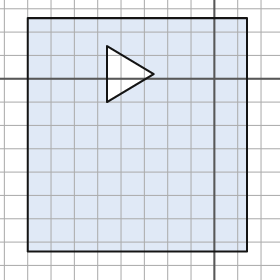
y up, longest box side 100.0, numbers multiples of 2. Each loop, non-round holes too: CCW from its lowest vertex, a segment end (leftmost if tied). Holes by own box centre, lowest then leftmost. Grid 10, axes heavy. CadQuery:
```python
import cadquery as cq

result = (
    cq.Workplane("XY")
    .moveTo(-80.0, -74.0)
    .lineTo(14.0, -74.0)
    .lineTo(14.0, 26.0)
    .lineTo(-80.0, 26.0)
    .close()
    .moveTo(-46.0, -10.0)
    .lineTo(-26.0, 2.0)
    .lineTo(-46.0, 14.0)
    .close()
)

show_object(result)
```